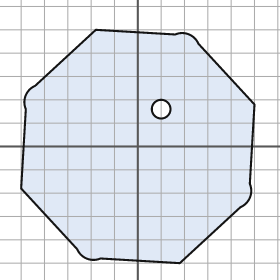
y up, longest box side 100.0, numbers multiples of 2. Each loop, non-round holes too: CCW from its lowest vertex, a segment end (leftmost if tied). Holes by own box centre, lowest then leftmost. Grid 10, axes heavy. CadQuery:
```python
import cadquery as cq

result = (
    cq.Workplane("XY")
    .moveTo(18.0, -50.0)
    .lineTo(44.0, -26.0)
    .threePointArc((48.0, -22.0), (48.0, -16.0))
    .lineTo(50.0, 18.0)
    .lineTo(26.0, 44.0)
    .threePointArc((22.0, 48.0), (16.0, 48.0))
    .lineTo(-18.0, 50.0)
    .lineTo(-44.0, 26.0)
    .threePointArc((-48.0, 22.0), (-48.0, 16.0))
    .lineTo(-50.0, -18.0)
    .lineTo(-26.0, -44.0)
    .threePointArc((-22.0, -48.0), (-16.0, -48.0))
    .close()
    .moveTo(10.0, 16.0)
    .circle(4.0)
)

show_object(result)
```